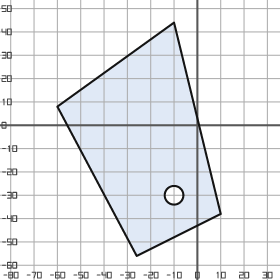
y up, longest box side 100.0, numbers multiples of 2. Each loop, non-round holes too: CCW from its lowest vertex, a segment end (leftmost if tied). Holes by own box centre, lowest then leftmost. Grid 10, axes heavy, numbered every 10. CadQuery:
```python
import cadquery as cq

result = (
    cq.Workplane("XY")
    .moveTo(-26.0, -56.0)
    .lineTo(10.0, -38.0)
    .lineTo(-10.0, 44.0)
    .lineTo(-60.0, 8.0)
    .close()
    .moveTo(-10.0, -30.0)
    .circle(4.0)
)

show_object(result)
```